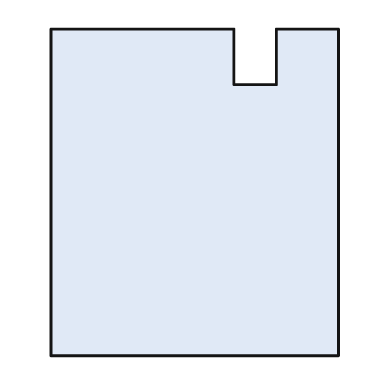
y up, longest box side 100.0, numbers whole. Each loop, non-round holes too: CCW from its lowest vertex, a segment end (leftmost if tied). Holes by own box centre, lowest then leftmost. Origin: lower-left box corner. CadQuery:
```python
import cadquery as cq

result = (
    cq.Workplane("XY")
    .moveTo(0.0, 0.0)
    .lineTo(88.0, 0.0)
    .lineTo(88.0, 100.0)
    .lineTo(69.0, 100.0)
    .lineTo(69.0, 83.0)
    .lineTo(56.0, 83.0)
    .lineTo(56.0, 100.0)
    .lineTo(0.0, 100.0)
    .close()
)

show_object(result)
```